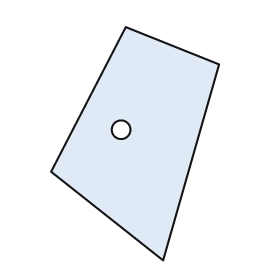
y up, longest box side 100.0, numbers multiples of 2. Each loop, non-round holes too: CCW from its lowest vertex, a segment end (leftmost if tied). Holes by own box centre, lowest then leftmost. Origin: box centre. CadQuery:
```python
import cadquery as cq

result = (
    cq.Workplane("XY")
    .moveTo(12.0, -50.0)
    .lineTo(36.0, 34.0)
    .lineTo(-4.0, 50.0)
    .lineTo(-36.0, -12.0)
    .close()
    .moveTo(-6.0, 6.0)
    .circle(4.0)
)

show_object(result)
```